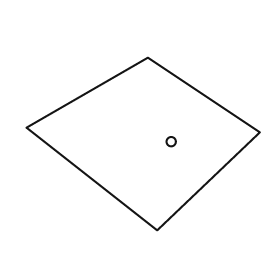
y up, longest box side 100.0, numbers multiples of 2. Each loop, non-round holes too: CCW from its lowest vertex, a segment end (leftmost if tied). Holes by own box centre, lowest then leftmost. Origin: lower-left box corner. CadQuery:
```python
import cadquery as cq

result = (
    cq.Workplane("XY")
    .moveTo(56.0, 0.0)
    .lineTo(100.0, 42.0)
    .lineTo(52.0, 74.0)
    .lineTo(0.0, 44.0)
    .close()
    .moveTo(62.0, 38.0)
    .circle(2.0)
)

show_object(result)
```